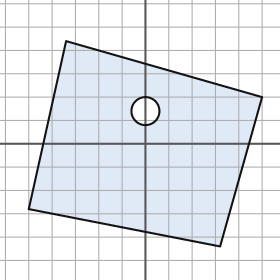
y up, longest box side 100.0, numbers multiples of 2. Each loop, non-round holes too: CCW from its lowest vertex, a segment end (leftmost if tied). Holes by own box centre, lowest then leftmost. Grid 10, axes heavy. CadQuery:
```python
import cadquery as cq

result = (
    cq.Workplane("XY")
    .moveTo(32.0, -44.0)
    .lineTo(50.0, 20.0)
    .lineTo(-34.0, 44.0)
    .lineTo(-50.0, -28.0)
    .close()
    .moveTo(0.0, 14.0)
    .circle(6.0)
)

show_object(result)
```